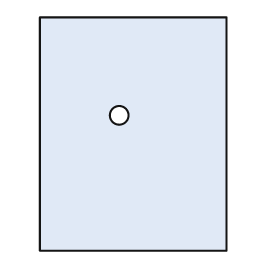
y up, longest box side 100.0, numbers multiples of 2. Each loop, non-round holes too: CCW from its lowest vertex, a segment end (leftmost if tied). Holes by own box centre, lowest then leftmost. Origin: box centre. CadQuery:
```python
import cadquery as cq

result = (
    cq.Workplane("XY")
    .moveTo(-40.0, -50.0)
    .lineTo(40.0, -50.0)
    .lineTo(40.0, 50.0)
    .lineTo(-40.0, 50.0)
    .close()
    .moveTo(-6.0, 8.0)
    .circle(4.0)
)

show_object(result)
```